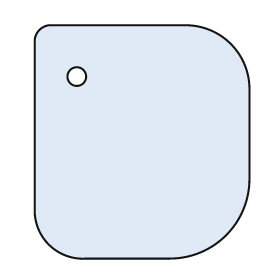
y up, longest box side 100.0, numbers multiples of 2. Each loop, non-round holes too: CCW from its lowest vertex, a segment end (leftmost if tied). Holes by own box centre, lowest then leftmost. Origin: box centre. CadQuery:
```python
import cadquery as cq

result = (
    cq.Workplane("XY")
    .moveTo(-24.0, -50.0)
    .lineTo(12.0, -50.0)
    .threePointArc((36.0, -40.0), (46.0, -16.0))
    .lineTo(46.0, 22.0)
    .threePointArc((38.0, 42.0), (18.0, 50.0))
    .lineTo(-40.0, 50.0)
    .threePointArc((-44.0, 48.0), (-46.0, 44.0))
    .lineTo(-46.0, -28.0)
    .threePointArc((-40.0, -44.0), (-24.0, -50.0))
    .close()
    .moveTo(-28.0, 28.0)
    .circle(4.0)
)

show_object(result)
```